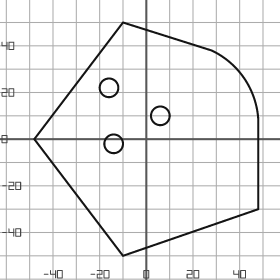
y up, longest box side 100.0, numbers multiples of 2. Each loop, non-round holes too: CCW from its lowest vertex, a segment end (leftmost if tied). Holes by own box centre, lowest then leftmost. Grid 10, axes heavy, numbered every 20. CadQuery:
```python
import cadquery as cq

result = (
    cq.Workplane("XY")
    .moveTo(-10.0, -50.0)
    .lineTo(48.0, -30.0)
    .lineTo(48.0, 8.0)
    .threePointArc((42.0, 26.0), (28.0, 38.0))
    .lineTo(-10.0, 50.0)
    .lineTo(-48.0, 0.0)
    .close()
    .moveTo(-14.0, -2.0)
    .circle(4.0)
    .moveTo(6.0, 10.0)
    .circle(4.0)
    .moveTo(-16.0, 22.0)
    .circle(4.0)
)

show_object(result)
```